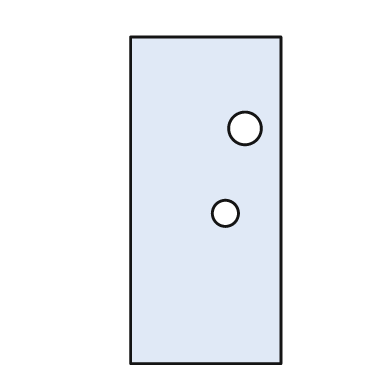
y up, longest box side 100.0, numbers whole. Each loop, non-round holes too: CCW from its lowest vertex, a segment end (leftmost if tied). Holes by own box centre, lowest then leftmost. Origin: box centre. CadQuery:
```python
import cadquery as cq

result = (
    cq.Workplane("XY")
    .moveTo(-23.0, -50.0)
    .lineTo(23.0, -50.0)
    .lineTo(23.0, 50.0)
    .lineTo(-23.0, 50.0)
    .close()
    .moveTo(6.0, -4.0)
    .circle(4.0)
    .moveTo(12.0, 22.0)
    .circle(5.0)
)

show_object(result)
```